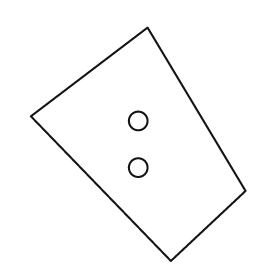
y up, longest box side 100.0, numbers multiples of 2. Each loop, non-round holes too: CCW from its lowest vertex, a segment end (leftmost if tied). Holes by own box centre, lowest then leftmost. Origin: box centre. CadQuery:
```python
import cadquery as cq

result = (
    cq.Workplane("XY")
    .moveTo(14.0, -50.0)
    .lineTo(46.0, -20.0)
    .lineTo(4.0, 50.0)
    .lineTo(-46.0, 12.0)
    .close()
    .moveTo(0.0, -10.0)
    .circle(4.0)
    .moveTo(0.0, 10.0)
    .circle(4.0)
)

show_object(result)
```